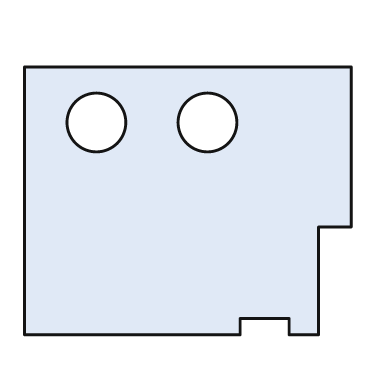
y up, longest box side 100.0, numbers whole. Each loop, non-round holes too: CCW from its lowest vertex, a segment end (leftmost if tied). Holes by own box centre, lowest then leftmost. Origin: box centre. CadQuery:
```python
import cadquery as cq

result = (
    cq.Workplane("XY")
    .moveTo(-50.0, -41.0)
    .lineTo(16.0, -41.0)
    .lineTo(16.0, -36.0)
    .lineTo(31.0, -36.0)
    .lineTo(31.0, -41.0)
    .lineTo(40.0, -41.0)
    .lineTo(40.0, -8.0)
    .lineTo(50.0, -8.0)
    .lineTo(50.0, 41.0)
    .lineTo(-50.0, 41.0)
    .close()
    .moveTo(-28.0, 24.0)
    .circle(9.0)
    .moveTo(6.0, 24.0)
    .circle(9.0)
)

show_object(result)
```